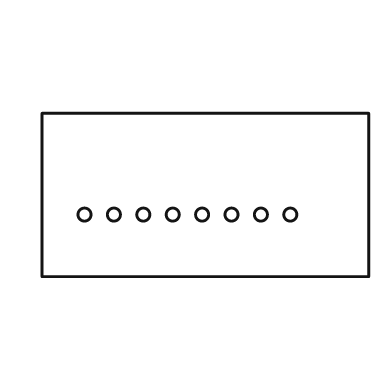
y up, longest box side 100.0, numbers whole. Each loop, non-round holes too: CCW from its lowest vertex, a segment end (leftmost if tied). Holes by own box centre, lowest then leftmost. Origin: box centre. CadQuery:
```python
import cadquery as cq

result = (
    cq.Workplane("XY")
    .moveTo(-50.0, -25.0)
    .lineTo(50.0, -25.0)
    .lineTo(50.0, 25.0)
    .lineTo(-50.0, 25.0)
    .close()
    .moveTo(-37.0, -6.0)
    .circle(2.0)
    .moveTo(-28.0, -6.0)
    .circle(2.0)
    .moveTo(-19.0, -6.0)
    .circle(2.0)
    .moveTo(-10.0, -6.0)
    .circle(2.0)
    .moveTo(-1.0, -6.0)
    .circle(2.0)
    .moveTo(8.0, -6.0)
    .circle(2.0)
    .moveTo(17.0, -6.0)
    .circle(2.0)
    .moveTo(26.0, -6.0)
    .circle(2.0)
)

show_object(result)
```